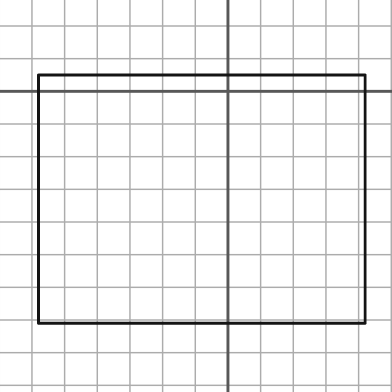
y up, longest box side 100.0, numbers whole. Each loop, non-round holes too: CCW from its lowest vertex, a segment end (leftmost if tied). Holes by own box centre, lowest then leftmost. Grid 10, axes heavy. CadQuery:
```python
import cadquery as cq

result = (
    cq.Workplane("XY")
    .moveTo(-58.0, -71.0)
    .lineTo(42.0, -71.0)
    .lineTo(42.0, 5.0)
    .lineTo(-58.0, 5.0)
    .close()
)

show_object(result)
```